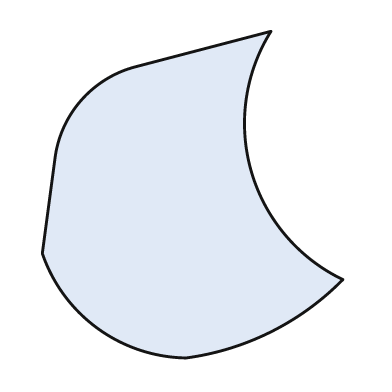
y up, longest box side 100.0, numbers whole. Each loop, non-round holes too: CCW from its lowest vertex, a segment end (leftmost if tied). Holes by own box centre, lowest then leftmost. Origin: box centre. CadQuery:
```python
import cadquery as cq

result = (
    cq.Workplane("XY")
    .moveTo(-2.0, -50.0)
    .threePointArc((24.0, -42.0), (46.0, -26.0))
    .threePointArc((18.0, 7.0), (24.0, 50.0))
    .lineTo(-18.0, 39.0)
    .threePointArc((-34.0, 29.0), (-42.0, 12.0))
    .lineTo(-46.0, -18.0)
    .threePointArc((-29.0, -41.0), (-2.0, -50.0))
    .close()
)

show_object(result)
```